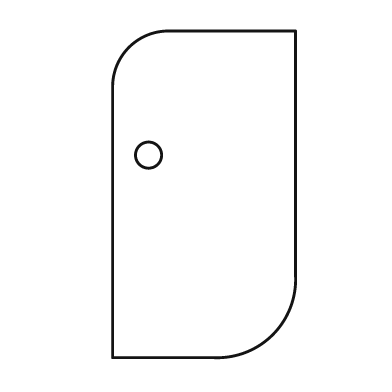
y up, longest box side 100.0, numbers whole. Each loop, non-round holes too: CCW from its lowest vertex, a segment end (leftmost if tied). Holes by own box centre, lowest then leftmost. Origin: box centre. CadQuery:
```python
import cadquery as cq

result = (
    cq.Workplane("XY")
    .moveTo(-28.0, -50.0)
    .lineTo(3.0, -50.0)
    .threePointArc((21.0, -43.0), (28.0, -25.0))
    .lineTo(28.0, 50.0)
    .lineTo(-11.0, 50.0)
    .threePointArc((-23.0, 45.0), (-28.0, 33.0))
    .close()
    .moveTo(-17.0, 12.0)
    .circle(4.0)
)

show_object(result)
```